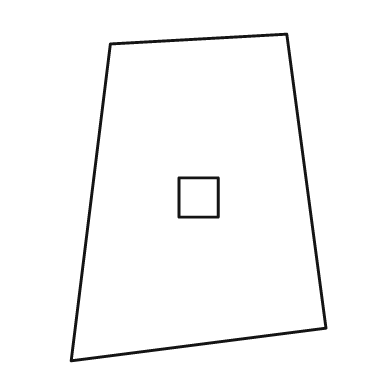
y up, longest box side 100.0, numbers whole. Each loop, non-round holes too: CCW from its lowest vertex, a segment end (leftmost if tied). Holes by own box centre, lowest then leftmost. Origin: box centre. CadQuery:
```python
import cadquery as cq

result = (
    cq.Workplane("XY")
    .moveTo(-39.0, -50.0)
    .lineTo(39.0, -40.0)
    .lineTo(27.0, 50.0)
    .lineTo(-27.0, 47.0)
    .close()
    .moveTo(-6.0, -6.0)
    .lineTo(6.0, -6.0)
    .lineTo(6.0, 6.0)
    .lineTo(-6.0, 6.0)
    .close()
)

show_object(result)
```